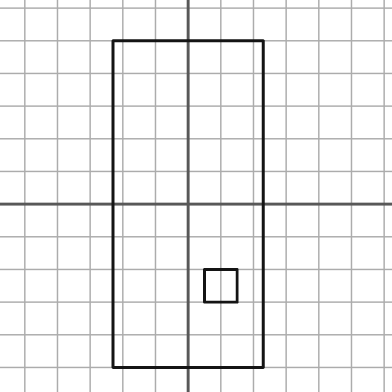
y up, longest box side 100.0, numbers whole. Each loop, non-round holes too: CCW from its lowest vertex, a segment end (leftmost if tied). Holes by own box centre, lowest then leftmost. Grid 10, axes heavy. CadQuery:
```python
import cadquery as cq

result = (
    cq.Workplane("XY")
    .moveTo(-23.0, -50.0)
    .lineTo(23.0, -50.0)
    .lineTo(23.0, 50.0)
    .lineTo(-23.0, 50.0)
    .close()
    .moveTo(5.0, -30.0)
    .lineTo(15.0, -30.0)
    .lineTo(15.0, -20.0)
    .lineTo(5.0, -20.0)
    .close()
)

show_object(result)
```